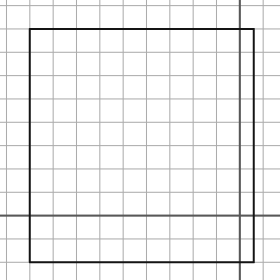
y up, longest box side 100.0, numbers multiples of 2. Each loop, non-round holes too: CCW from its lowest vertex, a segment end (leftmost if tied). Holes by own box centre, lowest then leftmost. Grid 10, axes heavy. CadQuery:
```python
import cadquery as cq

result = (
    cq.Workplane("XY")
    .moveTo(-90.0, -20.0)
    .lineTo(6.0, -20.0)
    .lineTo(6.0, 80.0)
    .lineTo(-90.0, 80.0)
    .close()
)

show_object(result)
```